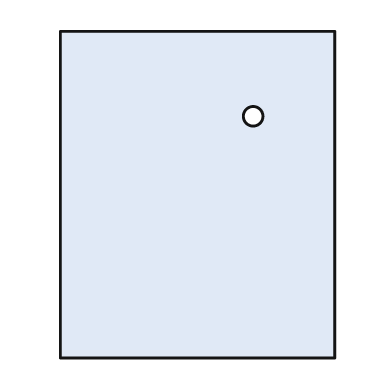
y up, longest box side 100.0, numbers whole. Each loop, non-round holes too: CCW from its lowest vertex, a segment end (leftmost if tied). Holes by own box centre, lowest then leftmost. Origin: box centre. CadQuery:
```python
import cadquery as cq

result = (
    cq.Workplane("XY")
    .moveTo(-42.0, -50.0)
    .lineTo(42.0, -50.0)
    .lineTo(42.0, 50.0)
    .lineTo(-42.0, 50.0)
    .close()
    .moveTo(17.0, 24.0)
    .circle(3.0)
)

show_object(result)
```